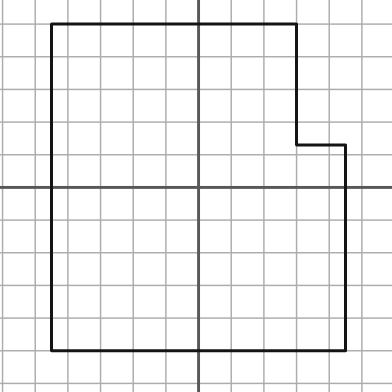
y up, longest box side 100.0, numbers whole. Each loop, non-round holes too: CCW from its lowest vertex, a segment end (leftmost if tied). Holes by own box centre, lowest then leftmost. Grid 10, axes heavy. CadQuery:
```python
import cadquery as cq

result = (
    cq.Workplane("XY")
    .moveTo(-45.0, -50.0)
    .lineTo(45.0, -50.0)
    .lineTo(45.0, 13.0)
    .lineTo(30.0, 13.0)
    .lineTo(30.0, 50.0)
    .lineTo(-45.0, 50.0)
    .close()
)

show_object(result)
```